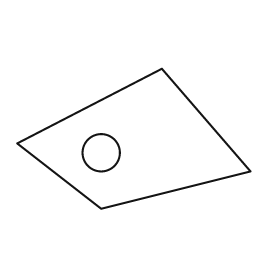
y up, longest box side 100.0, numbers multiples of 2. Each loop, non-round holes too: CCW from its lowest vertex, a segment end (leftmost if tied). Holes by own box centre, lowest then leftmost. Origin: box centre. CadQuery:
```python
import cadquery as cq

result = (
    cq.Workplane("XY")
    .moveTo(-14.0, -30.0)
    .lineTo(50.0, -14.0)
    .lineTo(12.0, 30.0)
    .lineTo(-50.0, -2.0)
    .close()
    .moveTo(-14.0, -6.0)
    .circle(8.0)
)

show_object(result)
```